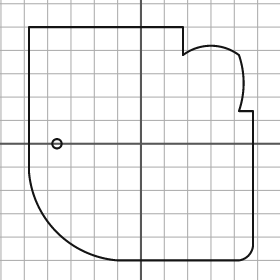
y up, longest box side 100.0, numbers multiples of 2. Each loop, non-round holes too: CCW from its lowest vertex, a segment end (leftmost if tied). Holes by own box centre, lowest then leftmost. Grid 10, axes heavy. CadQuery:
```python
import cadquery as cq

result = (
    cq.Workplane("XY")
    .moveTo(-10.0, -50.0)
    .lineTo(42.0, -50.0)
    .threePointArc((46.0, -48.0), (48.0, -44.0))
    .lineTo(48.0, 14.0)
    .lineTo(42.0, 14.0)
    .threePointArc((44.0, 26.0), (42.0, 38.0))
    .threePointArc((30.0, 42.0), (18.0, 38.0))
    .lineTo(18.0, 50.0)
    .lineTo(-48.0, 50.0)
    .lineTo(-48.0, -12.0)
    .threePointArc((-36.0, -38.0), (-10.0, -50.0))
    .close()
    .moveTo(-36.0, 0.0)
    .circle(2.0)
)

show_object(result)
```